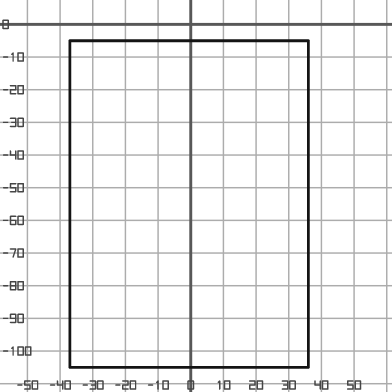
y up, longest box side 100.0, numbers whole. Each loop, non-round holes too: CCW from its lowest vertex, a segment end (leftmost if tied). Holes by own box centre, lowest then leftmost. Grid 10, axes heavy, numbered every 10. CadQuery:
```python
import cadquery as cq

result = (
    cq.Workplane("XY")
    .moveTo(-37.0, -105.0)
    .lineTo(36.0, -105.0)
    .lineTo(36.0, -5.0)
    .lineTo(-37.0, -5.0)
    .close()
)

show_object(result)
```